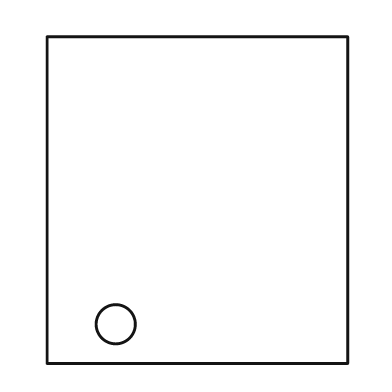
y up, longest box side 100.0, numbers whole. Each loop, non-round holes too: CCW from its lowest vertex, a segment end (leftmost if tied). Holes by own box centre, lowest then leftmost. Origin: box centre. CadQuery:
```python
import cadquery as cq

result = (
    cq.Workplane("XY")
    .moveTo(-46.0, -50.0)
    .lineTo(46.0, -50.0)
    .lineTo(46.0, 50.0)
    .lineTo(-46.0, 50.0)
    .close()
    .moveTo(-25.0, -38.0)
    .circle(6.0)
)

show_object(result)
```